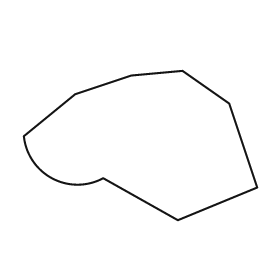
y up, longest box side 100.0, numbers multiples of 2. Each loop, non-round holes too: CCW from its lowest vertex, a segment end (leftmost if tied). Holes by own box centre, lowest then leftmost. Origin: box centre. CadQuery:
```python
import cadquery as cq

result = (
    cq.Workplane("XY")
    .moveTo(16.0, -32.0)
    .lineTo(50.0, -18.0)
    .lineTo(38.0, 18.0)
    .lineTo(18.0, 32.0)
    .lineTo(-4.0, 30.0)
    .lineTo(-28.0, 22.0)
    .lineTo(-50.0, 4.0)
    .threePointArc((-38.0, -14.0), (-16.0, -14.0))
    .close()
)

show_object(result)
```